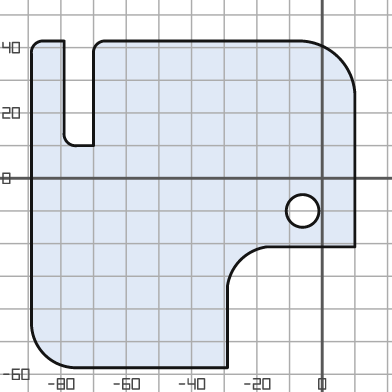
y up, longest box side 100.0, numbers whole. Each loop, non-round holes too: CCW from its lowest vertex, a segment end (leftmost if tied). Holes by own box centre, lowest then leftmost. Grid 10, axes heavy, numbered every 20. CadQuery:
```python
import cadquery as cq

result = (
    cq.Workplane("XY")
    .moveTo(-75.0, -58.0)
    .lineTo(-29.0, -58.0)
    .lineTo(-29.0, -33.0)
    .threePointArc((-25.0, -25.0), (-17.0, -21.0))
    .lineTo(10.0, -21.0)
    .lineTo(10.0, 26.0)
    .threePointArc((5.0, 37.0), (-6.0, 42.0))
    .lineTo(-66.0, 42.0)
    .threePointArc((-69.0, 41.0), (-70.0, 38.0))
    .lineTo(-70.0, 10.0)
    .lineTo(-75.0, 10.0)
    .threePointArc((-78.0, 11.0), (-79.0, 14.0))
    .lineTo(-79.0, 42.0)
    .lineTo(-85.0, 42.0)
    .threePointArc((-88.0, 41.0), (-89.0, 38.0))
    .lineTo(-89.0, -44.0)
    .threePointArc((-85.0, -54.0), (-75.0, -58.0))
    .close()
    .moveTo(-6.0, -10.0)
    .circle(5.0)
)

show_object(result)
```